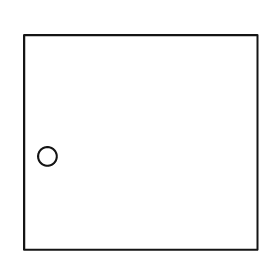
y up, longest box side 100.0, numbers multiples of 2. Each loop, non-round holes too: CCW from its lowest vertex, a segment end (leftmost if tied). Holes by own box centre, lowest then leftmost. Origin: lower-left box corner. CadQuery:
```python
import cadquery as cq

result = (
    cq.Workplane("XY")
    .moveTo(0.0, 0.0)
    .lineTo(100.0, 0.0)
    .lineTo(100.0, 92.0)
    .lineTo(0.0, 92.0)
    .close()
    .moveTo(10.0, 40.0)
    .circle(4.0)
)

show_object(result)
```